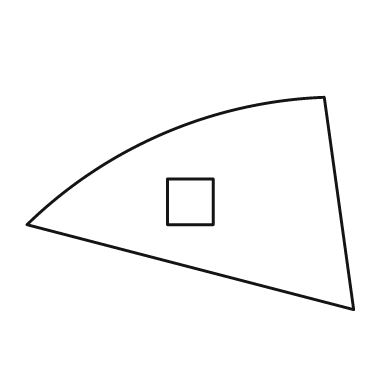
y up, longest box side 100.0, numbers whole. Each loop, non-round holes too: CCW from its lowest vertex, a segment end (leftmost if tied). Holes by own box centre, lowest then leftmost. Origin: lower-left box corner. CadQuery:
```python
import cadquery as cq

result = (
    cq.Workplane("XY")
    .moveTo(100.0, 0.0)
    .lineTo(91.0, 65.0)
    .threePointArc((42.0, 54.0), (0.0, 26.0))
    .close()
    .moveTo(43.0, 26.0)
    .lineTo(57.0, 26.0)
    .lineTo(57.0, 40.0)
    .lineTo(43.0, 40.0)
    .close()
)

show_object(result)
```